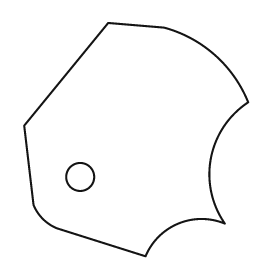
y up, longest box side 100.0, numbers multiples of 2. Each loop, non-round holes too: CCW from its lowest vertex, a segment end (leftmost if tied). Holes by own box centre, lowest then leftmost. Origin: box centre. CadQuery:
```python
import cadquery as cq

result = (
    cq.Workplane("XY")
    .moveTo(4.0, -50.0)
    .threePointArc((18.0, -36.0), (38.0, -36.0))
    .threePointArc((32.0, -8.0), (48.0, 16.0))
    .threePointArc((34.0, 36.0), (12.0, 48.0))
    .lineTo(-12.0, 50.0)
    .lineTo(-48.0, 6.0)
    .lineTo(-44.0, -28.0)
    .threePointArc((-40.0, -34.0), (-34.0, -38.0))
    .close()
    .moveTo(-24.0, -16.0)
    .circle(6.0)
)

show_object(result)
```